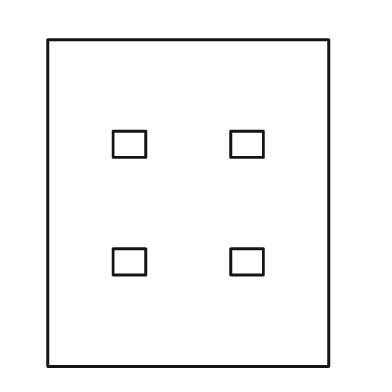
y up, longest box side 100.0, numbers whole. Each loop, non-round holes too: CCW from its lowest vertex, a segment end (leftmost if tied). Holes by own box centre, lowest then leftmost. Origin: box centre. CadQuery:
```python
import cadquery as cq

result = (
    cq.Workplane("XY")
    .moveTo(-43.0, -50.0)
    .lineTo(43.0, -50.0)
    .lineTo(43.0, 50.0)
    .lineTo(-43.0, 50.0)
    .close()
    .moveTo(-23.0, -22.0)
    .lineTo(-13.0, -22.0)
    .lineTo(-13.0, -14.0)
    .lineTo(-23.0, -14.0)
    .close()
    .moveTo(13.0, -22.0)
    .lineTo(23.0, -22.0)
    .lineTo(23.0, -14.0)
    .lineTo(13.0, -14.0)
    .close()
    .moveTo(-23.0, 14.0)
    .lineTo(-13.0, 14.0)
    .lineTo(-13.0, 22.0)
    .lineTo(-23.0, 22.0)
    .close()
    .moveTo(13.0, 14.0)
    .lineTo(23.0, 14.0)
    .lineTo(23.0, 22.0)
    .lineTo(13.0, 22.0)
    .close()
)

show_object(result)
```